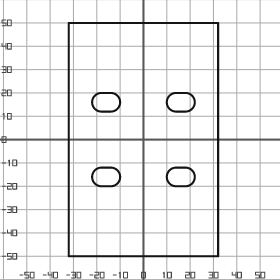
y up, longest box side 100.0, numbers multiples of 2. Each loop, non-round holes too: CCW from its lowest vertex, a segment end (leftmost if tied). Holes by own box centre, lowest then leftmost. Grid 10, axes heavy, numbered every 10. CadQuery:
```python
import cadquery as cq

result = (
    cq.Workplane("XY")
    .moveTo(-32.0, -50.0)
    .lineTo(32.0, -50.0)
    .lineTo(32.0, 50.0)
    .lineTo(-32.0, 50.0)
    .close()
    .moveTo(-18.0, -20.0)
    .lineTo(-14.0, -20.0)
    .threePointArc((-10.0, -16.0), (-14.0, -12.0))
    .lineTo(-18.0, -12.0)
    .threePointArc((-22.0, -16.0), (-18.0, -20.0))
    .close()
    .moveTo(14.0, -20.0)
    .lineTo(18.0, -20.0)
    .threePointArc((22.0, -16.0), (18.0, -12.0))
    .lineTo(14.0, -12.0)
    .threePointArc((10.0, -16.0), (14.0, -20.0))
    .close()
    .moveTo(-18.0, 12.0)
    .lineTo(-14.0, 12.0)
    .threePointArc((-10.0, 16.0), (-14.0, 20.0))
    .lineTo(-18.0, 20.0)
    .threePointArc((-22.0, 16.0), (-18.0, 12.0))
    .close()
    .moveTo(14.0, 12.0)
    .lineTo(18.0, 12.0)
    .threePointArc((22.0, 16.0), (18.0, 20.0))
    .lineTo(14.0, 20.0)
    .threePointArc((10.0, 16.0), (14.0, 12.0))
    .close()
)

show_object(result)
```